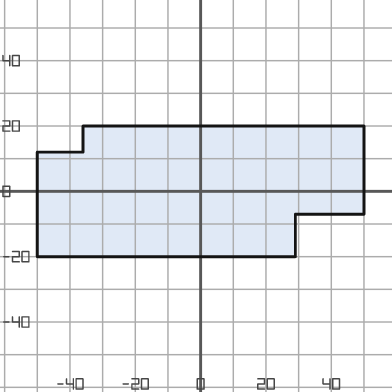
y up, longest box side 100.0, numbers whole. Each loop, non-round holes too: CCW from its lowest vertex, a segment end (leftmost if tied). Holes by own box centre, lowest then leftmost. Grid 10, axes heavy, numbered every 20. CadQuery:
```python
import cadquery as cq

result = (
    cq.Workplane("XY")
    .moveTo(-50.0, -20.0)
    .lineTo(29.0, -20.0)
    .lineTo(29.0, -7.0)
    .lineTo(50.0, -7.0)
    .lineTo(50.0, 20.0)
    .lineTo(-36.0, 20.0)
    .lineTo(-36.0, 12.0)
    .lineTo(-50.0, 12.0)
    .close()
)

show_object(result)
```